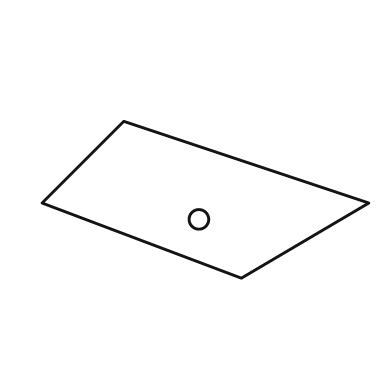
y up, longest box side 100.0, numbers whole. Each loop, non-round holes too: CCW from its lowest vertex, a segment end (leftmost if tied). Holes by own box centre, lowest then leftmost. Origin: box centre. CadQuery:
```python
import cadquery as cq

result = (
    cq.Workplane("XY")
    .moveTo(11.0, -24.0)
    .lineTo(50.0, -1.0)
    .lineTo(-25.0, 24.0)
    .lineTo(-50.0, -1.0)
    .close()
    .moveTo(-2.0, -6.0)
    .circle(3.0)
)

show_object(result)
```